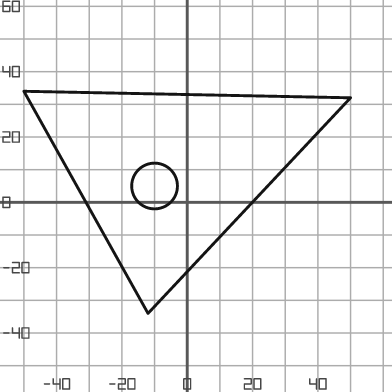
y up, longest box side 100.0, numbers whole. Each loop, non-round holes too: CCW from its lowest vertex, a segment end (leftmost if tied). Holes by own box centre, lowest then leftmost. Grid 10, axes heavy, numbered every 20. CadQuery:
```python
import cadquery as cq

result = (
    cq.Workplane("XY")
    .moveTo(-12.0, -34.0)
    .lineTo(50.0, 32.0)
    .lineTo(-50.0, 34.0)
    .close()
    .moveTo(-10.0, 5.0)
    .circle(7.0)
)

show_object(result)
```